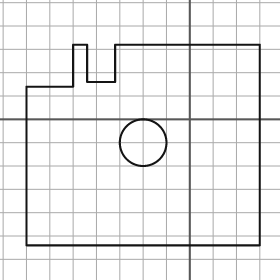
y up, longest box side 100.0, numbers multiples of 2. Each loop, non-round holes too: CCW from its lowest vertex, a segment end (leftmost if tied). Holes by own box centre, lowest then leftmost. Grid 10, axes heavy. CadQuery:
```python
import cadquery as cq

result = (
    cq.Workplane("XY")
    .moveTo(-70.0, -54.0)
    .lineTo(30.0, -54.0)
    .lineTo(30.0, 32.0)
    .lineTo(-32.0, 32.0)
    .lineTo(-32.0, 16.0)
    .lineTo(-44.0, 16.0)
    .lineTo(-44.0, 32.0)
    .lineTo(-50.0, 32.0)
    .lineTo(-50.0, 14.0)
    .lineTo(-70.0, 14.0)
    .close()
    .moveTo(-20.0, -10.0)
    .circle(10.0)
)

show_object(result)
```